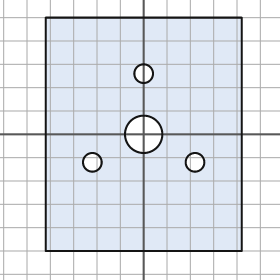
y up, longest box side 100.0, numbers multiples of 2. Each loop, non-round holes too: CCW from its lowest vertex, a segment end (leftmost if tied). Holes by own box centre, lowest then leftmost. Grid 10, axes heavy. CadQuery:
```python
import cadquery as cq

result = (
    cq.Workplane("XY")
    .moveTo(-42.0, -50.0)
    .lineTo(42.0, -50.0)
    .lineTo(42.0, 50.0)
    .lineTo(-42.0, 50.0)
    .close()
    .moveTo(-22.0, -12.0)
    .circle(4.0)
    .moveTo(22.0, -12.0)
    .circle(4.0)
    .moveTo(0.0, 0.0)
    .circle(8.0)
    .moveTo(0.0, 26.0)
    .circle(4.0)
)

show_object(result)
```